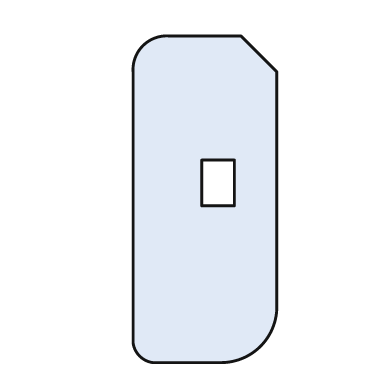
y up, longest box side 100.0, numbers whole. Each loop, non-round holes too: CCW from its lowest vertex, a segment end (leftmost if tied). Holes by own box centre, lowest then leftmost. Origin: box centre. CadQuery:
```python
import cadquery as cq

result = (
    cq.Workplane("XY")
    .moveTo(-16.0, -50.0)
    .lineTo(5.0, -50.0)
    .threePointArc((17.0, -45.0), (22.0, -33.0))
    .lineTo(22.0, 39.0)
    .lineTo(11.0, 50.0)
    .lineTo(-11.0, 50.0)
    .threePointArc((-19.0, 47.0), (-22.0, 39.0))
    .lineTo(-22.0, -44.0)
    .threePointArc((-20.0, -48.0), (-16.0, -50.0))
    .close()
    .moveTo(-1.0, -2.0)
    .lineTo(9.0, -2.0)
    .lineTo(9.0, 12.0)
    .lineTo(-1.0, 12.0)
    .close()
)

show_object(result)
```